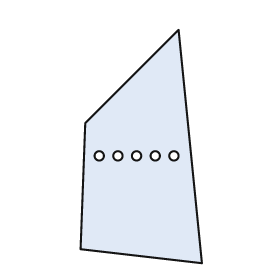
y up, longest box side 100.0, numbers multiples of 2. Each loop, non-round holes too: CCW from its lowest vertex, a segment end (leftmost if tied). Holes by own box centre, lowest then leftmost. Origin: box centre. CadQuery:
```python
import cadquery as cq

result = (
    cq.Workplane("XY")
    .moveTo(26.0, -50.0)
    .lineTo(16.0, 50.0)
    .lineTo(-24.0, 10.0)
    .lineTo(-26.0, -44.0)
    .close()
    .moveTo(-18.0, -4.0)
    .circle(2.0)
    .moveTo(-10.0, -4.0)
    .circle(2.0)
    .moveTo(-2.0, -4.0)
    .circle(2.0)
    .moveTo(6.0, -4.0)
    .circle(2.0)
    .moveTo(14.0, -4.0)
    .circle(2.0)
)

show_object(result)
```